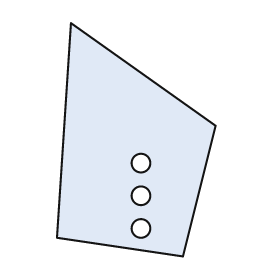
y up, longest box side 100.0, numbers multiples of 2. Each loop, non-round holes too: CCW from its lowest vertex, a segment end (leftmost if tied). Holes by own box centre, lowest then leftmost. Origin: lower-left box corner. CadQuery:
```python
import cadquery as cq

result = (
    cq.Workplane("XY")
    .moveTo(54.0, 0.0)
    .lineTo(68.0, 56.0)
    .lineTo(6.0, 100.0)
    .lineTo(0.0, 8.0)
    .close()
    .moveTo(36.0, 12.0)
    .circle(4.0)
    .moveTo(36.0, 26.0)
    .circle(4.0)
    .moveTo(36.0, 40.0)
    .circle(4.0)
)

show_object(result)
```